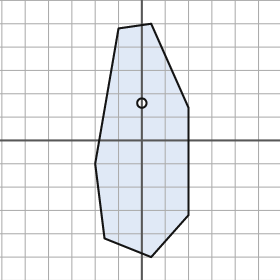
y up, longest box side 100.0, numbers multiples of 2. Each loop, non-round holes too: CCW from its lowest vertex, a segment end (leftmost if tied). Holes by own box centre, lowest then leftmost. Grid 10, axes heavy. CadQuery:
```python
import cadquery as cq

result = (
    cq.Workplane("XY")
    .moveTo(4.0, -50.0)
    .lineTo(20.0, -32.0)
    .lineTo(20.0, 14.0)
    .lineTo(4.0, 50.0)
    .lineTo(-10.0, 48.0)
    .lineTo(-20.0, -10.0)
    .lineTo(-16.0, -42.0)
    .close()
    .moveTo(0.0, 16.0)
    .circle(2.0)
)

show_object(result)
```